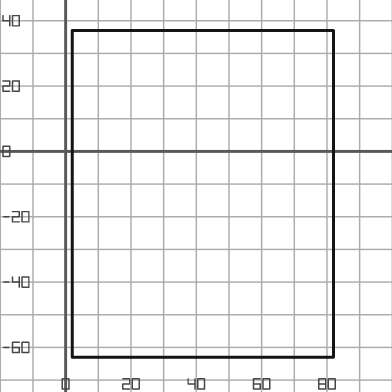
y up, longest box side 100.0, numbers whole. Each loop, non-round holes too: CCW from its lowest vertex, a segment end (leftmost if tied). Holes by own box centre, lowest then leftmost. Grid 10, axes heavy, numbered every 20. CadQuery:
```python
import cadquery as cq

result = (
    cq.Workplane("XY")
    .moveTo(2.0, -63.0)
    .lineTo(82.0, -63.0)
    .lineTo(82.0, 37.0)
    .lineTo(2.0, 37.0)
    .close()
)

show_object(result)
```